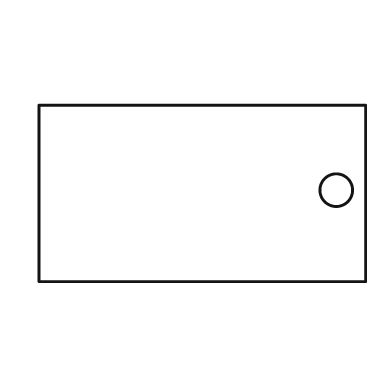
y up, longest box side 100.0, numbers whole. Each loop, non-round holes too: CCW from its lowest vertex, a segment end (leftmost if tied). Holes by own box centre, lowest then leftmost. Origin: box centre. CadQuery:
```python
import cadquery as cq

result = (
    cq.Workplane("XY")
    .moveTo(-50.0, -27.0)
    .lineTo(50.0, -27.0)
    .lineTo(50.0, 27.0)
    .lineTo(-50.0, 27.0)
    .close()
    .moveTo(41.0, 1.0)
    .circle(5.0)
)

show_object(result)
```